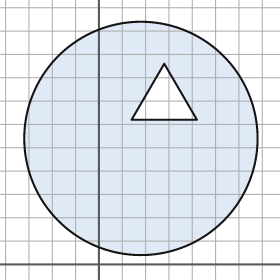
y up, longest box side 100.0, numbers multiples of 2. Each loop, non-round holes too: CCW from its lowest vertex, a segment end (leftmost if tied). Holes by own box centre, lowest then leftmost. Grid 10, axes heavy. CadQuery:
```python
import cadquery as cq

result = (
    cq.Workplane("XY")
    .moveTo(18.0, 54.0)
    .circle(50.0)
    .moveTo(14.0, 62.0)
    .lineTo(42.0, 62.0)
    .lineTo(28.0, 86.0)
    .close()
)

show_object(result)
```